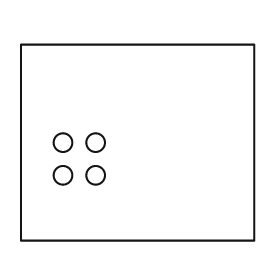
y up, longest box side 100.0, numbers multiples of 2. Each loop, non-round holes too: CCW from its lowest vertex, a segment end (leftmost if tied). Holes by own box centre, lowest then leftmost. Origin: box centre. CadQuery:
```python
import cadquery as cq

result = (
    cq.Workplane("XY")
    .moveTo(-50.0, -42.0)
    .lineTo(50.0, -42.0)
    .lineTo(50.0, 42.0)
    .lineTo(-50.0, 42.0)
    .close()
    .moveTo(-32.0, -14.0)
    .circle(4.0)
    .moveTo(-18.0, -14.0)
    .circle(4.0)
    .moveTo(-32.0, 0.0)
    .circle(4.0)
    .moveTo(-18.0, 0.0)
    .circle(4.0)
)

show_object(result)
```